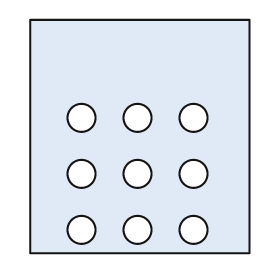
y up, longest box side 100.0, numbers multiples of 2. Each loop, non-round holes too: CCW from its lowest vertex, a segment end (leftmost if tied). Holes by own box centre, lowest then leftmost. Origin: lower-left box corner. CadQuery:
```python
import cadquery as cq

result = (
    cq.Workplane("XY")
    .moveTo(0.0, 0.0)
    .lineTo(94.0, 0.0)
    .lineTo(94.0, 100.0)
    .lineTo(0.0, 100.0)
    .close()
    .moveTo(22.0, 10.0)
    .circle(6.0)
    .moveTo(46.0, 10.0)
    .circle(6.0)
    .moveTo(70.0, 10.0)
    .circle(6.0)
    .moveTo(22.0, 34.0)
    .circle(6.0)
    .moveTo(46.0, 34.0)
    .circle(6.0)
    .moveTo(70.0, 34.0)
    .circle(6.0)
    .moveTo(22.0, 58.0)
    .circle(6.0)
    .moveTo(46.0, 58.0)
    .circle(6.0)
    .moveTo(70.0, 58.0)
    .circle(6.0)
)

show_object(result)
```